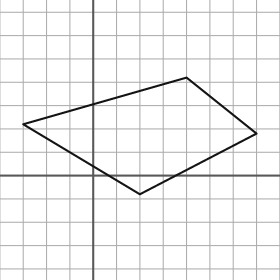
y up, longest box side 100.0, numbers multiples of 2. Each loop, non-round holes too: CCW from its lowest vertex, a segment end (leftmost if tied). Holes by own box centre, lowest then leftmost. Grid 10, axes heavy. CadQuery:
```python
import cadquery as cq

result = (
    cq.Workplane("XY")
    .moveTo(20.0, -8.0)
    .lineTo(70.0, 18.0)
    .lineTo(40.0, 42.0)
    .lineTo(-30.0, 22.0)
    .close()
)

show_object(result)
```